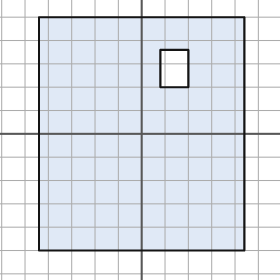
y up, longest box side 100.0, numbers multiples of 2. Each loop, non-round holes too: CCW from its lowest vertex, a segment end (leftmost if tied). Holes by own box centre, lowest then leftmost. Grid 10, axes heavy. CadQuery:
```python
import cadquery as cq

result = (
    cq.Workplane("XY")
    .moveTo(-44.0, -50.0)
    .lineTo(44.0, -50.0)
    .lineTo(44.0, 50.0)
    .lineTo(-44.0, 50.0)
    .close()
    .moveTo(8.0, 20.0)
    .lineTo(20.0, 20.0)
    .lineTo(20.0, 36.0)
    .lineTo(8.0, 36.0)
    .close()
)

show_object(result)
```